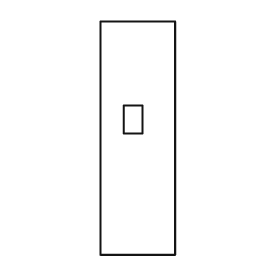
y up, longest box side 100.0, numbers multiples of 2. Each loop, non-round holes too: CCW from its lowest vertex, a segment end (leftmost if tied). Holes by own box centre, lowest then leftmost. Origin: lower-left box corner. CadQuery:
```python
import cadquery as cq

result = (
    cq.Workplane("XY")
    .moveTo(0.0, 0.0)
    .lineTo(32.0, 0.0)
    .lineTo(32.0, 100.0)
    .lineTo(0.0, 100.0)
    .close()
    .moveTo(10.0, 52.0)
    .lineTo(18.0, 52.0)
    .lineTo(18.0, 64.0)
    .lineTo(10.0, 64.0)
    .close()
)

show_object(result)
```